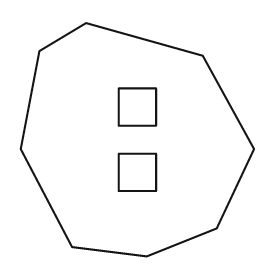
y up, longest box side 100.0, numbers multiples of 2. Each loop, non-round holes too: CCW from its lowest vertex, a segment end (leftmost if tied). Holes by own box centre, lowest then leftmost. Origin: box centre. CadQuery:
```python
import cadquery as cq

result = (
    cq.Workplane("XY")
    .moveTo(4.0, -50.0)
    .lineTo(34.0, -38.0)
    .lineTo(50.0, -4.0)
    .lineTo(28.0, 36.0)
    .lineTo(-22.0, 50.0)
    .lineTo(-42.0, 38.0)
    .lineTo(-50.0, -4.0)
    .lineTo(-28.0, -46.0)
    .close()
    .moveTo(-8.0, -22.0)
    .lineTo(8.0, -22.0)
    .lineTo(8.0, -6.0)
    .lineTo(-8.0, -6.0)
    .close()
    .moveTo(-8.0, 6.0)
    .lineTo(8.0, 6.0)
    .lineTo(8.0, 22.0)
    .lineTo(-8.0, 22.0)
    .close()
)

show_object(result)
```